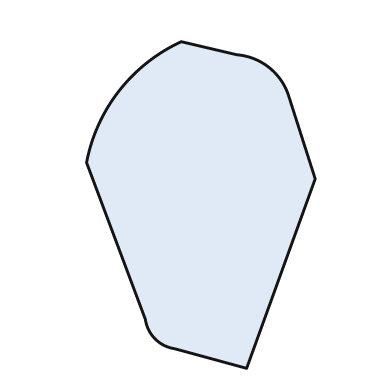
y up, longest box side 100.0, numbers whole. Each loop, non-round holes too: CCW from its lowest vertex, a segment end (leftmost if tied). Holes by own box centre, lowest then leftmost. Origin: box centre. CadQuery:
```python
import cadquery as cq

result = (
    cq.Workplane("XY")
    .moveTo(14.0, -50.0)
    .lineTo(35.0, 8.0)
    .lineTo(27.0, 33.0)
    .threePointArc((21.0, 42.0), (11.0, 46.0))
    .lineTo(-6.0, 50.0)
    .threePointArc((-25.0, 35.0), (-35.0, 13.0))
    .lineTo(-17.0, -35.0)
    .threePointArc((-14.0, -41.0), (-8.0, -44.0))
    .close()
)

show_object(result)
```